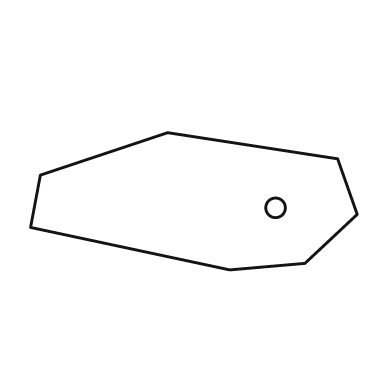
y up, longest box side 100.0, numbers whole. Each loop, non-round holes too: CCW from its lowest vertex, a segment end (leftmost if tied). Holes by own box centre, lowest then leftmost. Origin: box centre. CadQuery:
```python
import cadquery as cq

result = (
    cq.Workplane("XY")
    .moveTo(11.0, -21.0)
    .lineTo(34.0, -19.0)
    .lineTo(50.0, -4.0)
    .lineTo(44.0, 13.0)
    .lineTo(-8.0, 21.0)
    .lineTo(-47.0, 8.0)
    .lineTo(-50.0, -8.0)
    .close()
    .moveTo(25.0, -2.0)
    .circle(3.0)
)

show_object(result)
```